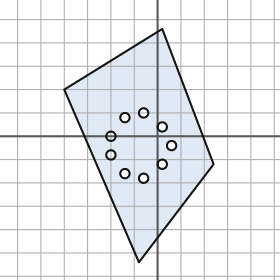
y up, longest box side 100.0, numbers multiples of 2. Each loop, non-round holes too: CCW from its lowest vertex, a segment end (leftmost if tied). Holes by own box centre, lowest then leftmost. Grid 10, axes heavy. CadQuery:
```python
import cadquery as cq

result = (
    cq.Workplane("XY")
    .moveTo(-8.0, -54.0)
    .lineTo(24.0, -12.0)
    .lineTo(2.0, 46.0)
    .lineTo(-40.0, 20.0)
    .close()
    .moveTo(-6.0, -18.0)
    .circle(2.0)
    .moveTo(-14.0, -16.0)
    .circle(2.0)
    .moveTo(2.0, -12.0)
    .circle(2.0)
    .moveTo(-20.0, -8.0)
    .circle(2.0)
    .moveTo(6.0, -4.0)
    .circle(2.0)
    .moveTo(-20.0, 0.0)
    .circle(2.0)
    .moveTo(2.0, 4.0)
    .circle(2.0)
    .moveTo(-14.0, 8.0)
    .circle(2.0)
    .moveTo(-6.0, 10.0)
    .circle(2.0)
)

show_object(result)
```